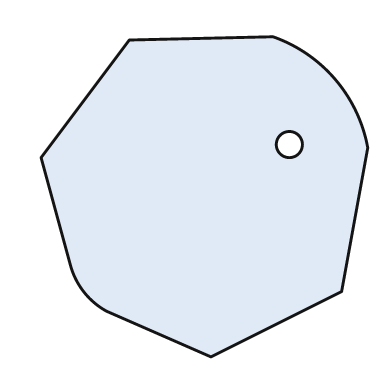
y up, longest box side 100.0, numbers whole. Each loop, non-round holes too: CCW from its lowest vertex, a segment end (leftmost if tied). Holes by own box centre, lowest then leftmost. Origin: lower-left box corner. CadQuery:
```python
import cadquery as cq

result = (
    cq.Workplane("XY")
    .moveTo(52.0, 0.0)
    .lineTo(92.0, 20.0)
    .lineTo(100.0, 64.0)
    .threePointArc((90.0, 85.0), (71.0, 98.0))
    .lineTo(27.0, 97.0)
    .lineTo(0.0, 61.0)
    .lineTo(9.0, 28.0)
    .threePointArc((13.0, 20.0), (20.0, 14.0))
    .close()
    .moveTo(76.0, 65.0)
    .circle(4.0)
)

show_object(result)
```